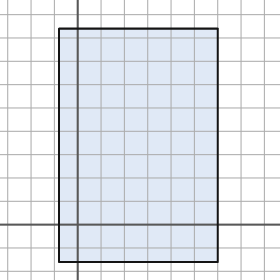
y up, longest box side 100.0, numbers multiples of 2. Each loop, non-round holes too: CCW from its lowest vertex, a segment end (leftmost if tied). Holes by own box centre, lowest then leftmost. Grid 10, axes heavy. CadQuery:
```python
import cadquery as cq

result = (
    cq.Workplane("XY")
    .moveTo(-8.0, -16.0)
    .lineTo(60.0, -16.0)
    .lineTo(60.0, 84.0)
    .lineTo(-8.0, 84.0)
    .close()
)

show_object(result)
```